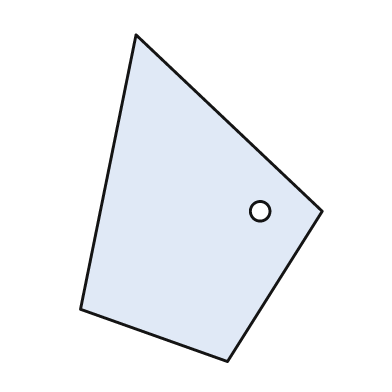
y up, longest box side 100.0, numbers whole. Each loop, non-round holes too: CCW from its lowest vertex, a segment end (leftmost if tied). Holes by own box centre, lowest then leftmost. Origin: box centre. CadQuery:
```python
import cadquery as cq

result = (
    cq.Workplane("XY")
    .moveTo(8.0, -50.0)
    .lineTo(37.0, -4.0)
    .lineTo(-20.0, 50.0)
    .lineTo(-37.0, -34.0)
    .close()
    .moveTo(18.0, -4.0)
    .circle(3.0)
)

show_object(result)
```